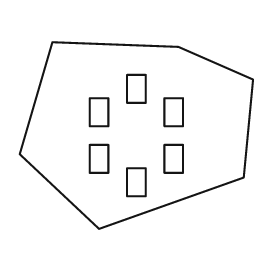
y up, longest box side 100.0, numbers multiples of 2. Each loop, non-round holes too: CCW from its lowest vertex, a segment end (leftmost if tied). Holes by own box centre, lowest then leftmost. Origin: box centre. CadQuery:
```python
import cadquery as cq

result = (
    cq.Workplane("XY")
    .moveTo(-16.0, -40.0)
    .lineTo(46.0, -18.0)
    .lineTo(50.0, 24.0)
    .lineTo(18.0, 38.0)
    .lineTo(-36.0, 40.0)
    .lineTo(-50.0, -8.0)
    .close()
    .moveTo(-4.0, -26.0)
    .lineTo(4.0, -26.0)
    .lineTo(4.0, -14.0)
    .lineTo(-4.0, -14.0)
    .close()
    .moveTo(-20.0, -16.0)
    .lineTo(-12.0, -16.0)
    .lineTo(-12.0, -4.0)
    .lineTo(-20.0, -4.0)
    .close()
    .moveTo(12.0, -16.0)
    .lineTo(20.0, -16.0)
    .lineTo(20.0, -4.0)
    .lineTo(12.0, -4.0)
    .close()
    .moveTo(-20.0, 4.0)
    .lineTo(-12.0, 4.0)
    .lineTo(-12.0, 16.0)
    .lineTo(-20.0, 16.0)
    .close()
    .moveTo(12.0, 4.0)
    .lineTo(20.0, 4.0)
    .lineTo(20.0, 16.0)
    .lineTo(12.0, 16.0)
    .close()
    .moveTo(-4.0, 14.0)
    .lineTo(4.0, 14.0)
    .lineTo(4.0, 26.0)
    .lineTo(-4.0, 26.0)
    .close()
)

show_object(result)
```